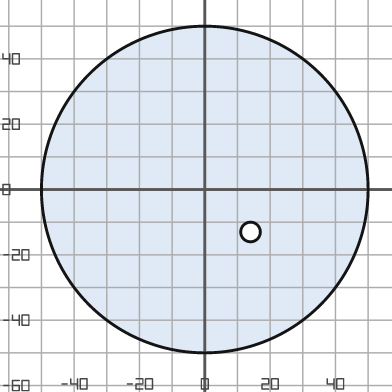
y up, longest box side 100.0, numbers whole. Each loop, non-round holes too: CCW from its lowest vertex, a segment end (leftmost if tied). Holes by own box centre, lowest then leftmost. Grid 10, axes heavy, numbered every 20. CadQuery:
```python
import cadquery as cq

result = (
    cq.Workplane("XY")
    .moveTo(0.0, 0.0)
    .circle(50.0)
    .moveTo(14.0, -13.0)
    .circle(3.0)
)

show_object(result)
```